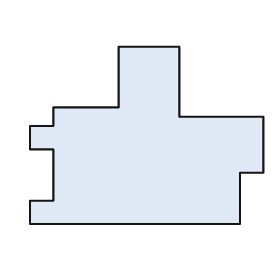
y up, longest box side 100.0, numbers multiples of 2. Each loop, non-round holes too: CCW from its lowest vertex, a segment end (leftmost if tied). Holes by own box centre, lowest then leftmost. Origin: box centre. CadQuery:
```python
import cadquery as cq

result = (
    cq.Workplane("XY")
    .moveTo(-50.0, -38.0)
    .lineTo(40.0, -38.0)
    .lineTo(40.0, -16.0)
    .lineTo(50.0, -16.0)
    .lineTo(50.0, 8.0)
    .lineTo(14.0, 8.0)
    .lineTo(14.0, 38.0)
    .lineTo(-12.0, 38.0)
    .lineTo(-12.0, 12.0)
    .lineTo(-40.0, 12.0)
    .lineTo(-40.0, 4.0)
    .lineTo(-50.0, 4.0)
    .lineTo(-50.0, -6.0)
    .lineTo(-40.0, -6.0)
    .lineTo(-40.0, -28.0)
    .lineTo(-50.0, -28.0)
    .close()
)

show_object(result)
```